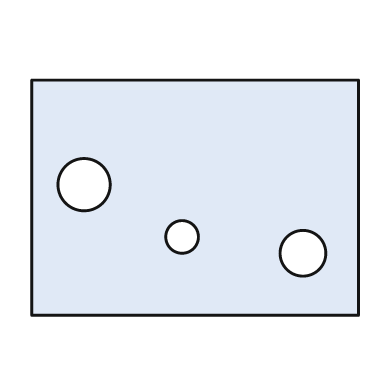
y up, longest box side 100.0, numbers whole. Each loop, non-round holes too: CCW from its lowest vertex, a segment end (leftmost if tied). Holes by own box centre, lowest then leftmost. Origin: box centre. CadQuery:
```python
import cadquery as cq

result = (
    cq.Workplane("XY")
    .moveTo(-50.0, -36.0)
    .lineTo(50.0, -36.0)
    .lineTo(50.0, 36.0)
    .lineTo(-50.0, 36.0)
    .close()
    .moveTo(33.0, -17.0)
    .circle(7.0)
    .moveTo(-4.0, -12.0)
    .circle(5.0)
    .moveTo(-34.0, 4.0)
    .circle(8.0)
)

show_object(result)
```